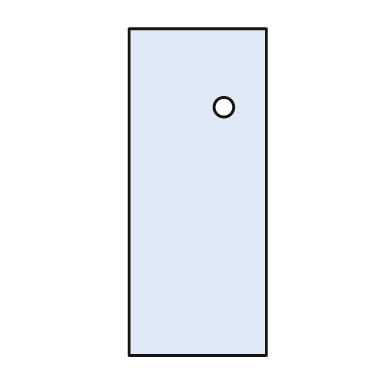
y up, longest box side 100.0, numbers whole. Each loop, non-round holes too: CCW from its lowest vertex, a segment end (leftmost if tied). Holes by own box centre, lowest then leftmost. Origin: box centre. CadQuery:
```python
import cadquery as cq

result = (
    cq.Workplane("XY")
    .moveTo(-21.0, -50.0)
    .lineTo(21.0, -50.0)
    .lineTo(21.0, 50.0)
    .lineTo(-21.0, 50.0)
    .close()
    .moveTo(8.0, 26.0)
    .circle(3.0)
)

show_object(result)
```